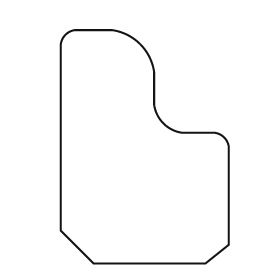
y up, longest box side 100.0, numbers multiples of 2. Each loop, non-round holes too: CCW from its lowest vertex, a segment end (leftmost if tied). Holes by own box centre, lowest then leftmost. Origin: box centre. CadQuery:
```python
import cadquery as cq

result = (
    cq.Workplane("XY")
    .moveTo(-22.0, -50.0)
    .lineTo(26.0, -50.0)
    .lineTo(36.0, -42.0)
    .lineTo(36.0, 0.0)
    .threePointArc((34.0, 4.0), (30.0, 6.0))
    .lineTo(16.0, 6.0)
    .threePointArc((8.0, 10.0), (4.0, 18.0))
    .lineTo(4.0, 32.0)
    .threePointArc((-2.0, 44.0), (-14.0, 50.0))
    .lineTo(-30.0, 50.0)
    .threePointArc((-34.0, 48.0), (-36.0, 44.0))
    .lineTo(-36.0, -36.0)
    .close()
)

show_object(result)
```